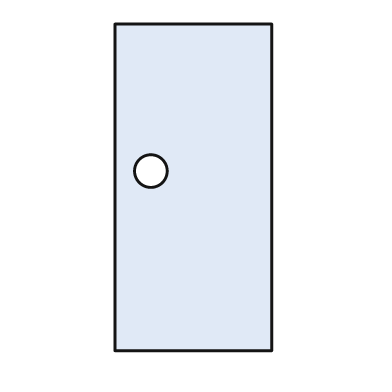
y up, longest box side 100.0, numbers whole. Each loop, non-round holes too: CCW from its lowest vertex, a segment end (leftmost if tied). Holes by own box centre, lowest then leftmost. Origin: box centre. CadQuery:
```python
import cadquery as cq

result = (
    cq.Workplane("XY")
    .moveTo(-24.0, -50.0)
    .lineTo(24.0, -50.0)
    .lineTo(24.0, 50.0)
    .lineTo(-24.0, 50.0)
    .close()
    .moveTo(-13.0, 5.0)
    .circle(5.0)
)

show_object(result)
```